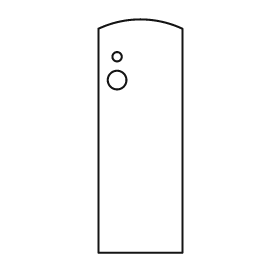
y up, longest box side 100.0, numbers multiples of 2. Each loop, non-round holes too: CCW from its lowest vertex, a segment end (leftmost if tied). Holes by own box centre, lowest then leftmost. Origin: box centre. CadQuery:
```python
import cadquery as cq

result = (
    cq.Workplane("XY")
    .moveTo(-18.0, -50.0)
    .lineTo(18.0, -50.0)
    .lineTo(18.0, 46.0)
    .threePointArc((0.0, 50.0), (-18.0, 46.0))
    .close()
    .moveTo(-10.0, 24.0)
    .circle(4.0)
    .moveTo(-10.0, 34.0)
    .circle(2.0)
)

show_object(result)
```